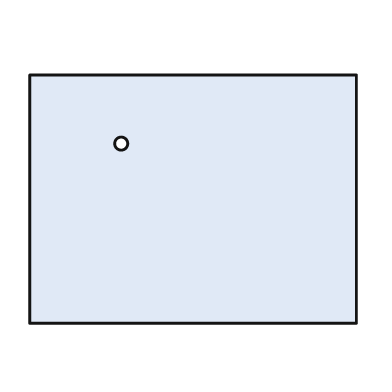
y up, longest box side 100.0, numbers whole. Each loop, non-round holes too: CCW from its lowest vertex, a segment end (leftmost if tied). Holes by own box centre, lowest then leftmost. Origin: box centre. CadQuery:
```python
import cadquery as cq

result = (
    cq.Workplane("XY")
    .moveTo(-50.0, -38.0)
    .lineTo(50.0, -38.0)
    .lineTo(50.0, 38.0)
    .lineTo(-50.0, 38.0)
    .close()
    .moveTo(-22.0, 17.0)
    .circle(2.0)
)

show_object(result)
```